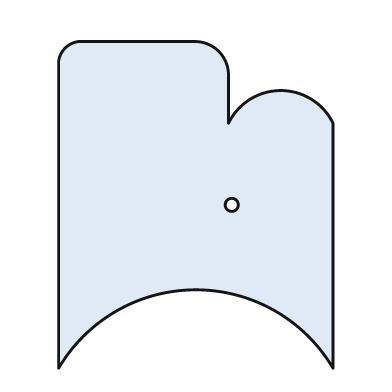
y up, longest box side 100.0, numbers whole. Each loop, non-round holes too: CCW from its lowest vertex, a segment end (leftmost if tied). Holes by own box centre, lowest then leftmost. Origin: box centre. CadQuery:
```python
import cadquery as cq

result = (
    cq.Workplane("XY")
    .moveTo(-42.0, -50.0)
    .threePointArc((0.0, -26.0), (42.0, -50.0))
    .lineTo(42.0, 25.0)
    .threePointArc((26.0, 35.0), (10.0, 25.0))
    .lineTo(10.0, 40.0)
    .threePointArc((7.0, 47.0), (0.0, 50.0))
    .lineTo(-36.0, 50.0)
    .threePointArc((-40.0, 48.0), (-42.0, 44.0))
    .close()
    .moveTo(11.0, 0.0)
    .circle(2.0)
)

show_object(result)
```